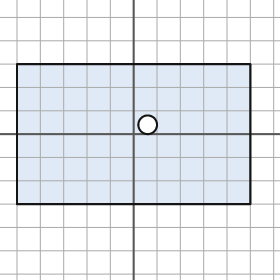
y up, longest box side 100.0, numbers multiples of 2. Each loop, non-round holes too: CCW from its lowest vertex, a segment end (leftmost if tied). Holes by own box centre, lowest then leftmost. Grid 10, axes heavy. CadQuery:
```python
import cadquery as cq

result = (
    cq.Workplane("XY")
    .moveTo(-50.0, -30.0)
    .lineTo(50.0, -30.0)
    .lineTo(50.0, 30.0)
    .lineTo(-50.0, 30.0)
    .close()
    .moveTo(6.0, 4.0)
    .circle(4.0)
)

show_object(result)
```